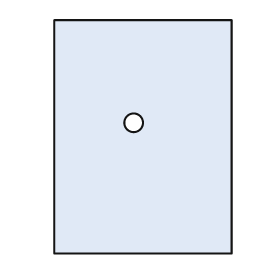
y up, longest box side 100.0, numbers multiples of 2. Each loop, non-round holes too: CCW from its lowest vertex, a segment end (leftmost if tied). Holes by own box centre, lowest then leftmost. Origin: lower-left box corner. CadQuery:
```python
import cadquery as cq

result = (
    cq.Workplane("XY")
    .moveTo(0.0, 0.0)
    .lineTo(76.0, 0.0)
    .lineTo(76.0, 100.0)
    .lineTo(0.0, 100.0)
    .close()
    .moveTo(34.0, 56.0)
    .circle(4.0)
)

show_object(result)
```